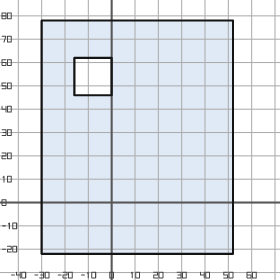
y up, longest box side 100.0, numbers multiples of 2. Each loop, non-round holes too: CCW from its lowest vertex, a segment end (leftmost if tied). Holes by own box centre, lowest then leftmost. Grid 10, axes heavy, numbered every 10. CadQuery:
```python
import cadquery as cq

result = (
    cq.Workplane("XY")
    .moveTo(-30.0, -22.0)
    .lineTo(52.0, -22.0)
    .lineTo(52.0, 78.0)
    .lineTo(-30.0, 78.0)
    .close()
    .moveTo(-16.0, 46.0)
    .lineTo(0.0, 46.0)
    .lineTo(0.0, 62.0)
    .lineTo(-16.0, 62.0)
    .close()
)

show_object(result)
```